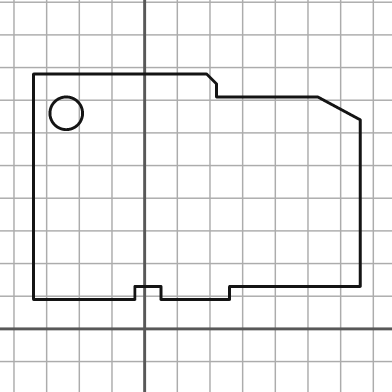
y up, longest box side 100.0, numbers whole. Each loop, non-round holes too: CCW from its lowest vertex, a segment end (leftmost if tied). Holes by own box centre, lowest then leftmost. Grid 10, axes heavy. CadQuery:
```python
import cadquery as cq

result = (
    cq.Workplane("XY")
    .moveTo(-34.0, 9.0)
    .lineTo(-3.0, 9.0)
    .lineTo(-3.0, 13.0)
    .lineTo(5.0, 13.0)
    .lineTo(5.0, 9.0)
    .lineTo(26.0, 9.0)
    .lineTo(26.0, 13.0)
    .lineTo(66.0, 13.0)
    .lineTo(66.0, 64.0)
    .lineTo(53.0, 71.0)
    .lineTo(22.0, 71.0)
    .lineTo(22.0, 75.0)
    .lineTo(19.0, 78.0)
    .lineTo(-34.0, 78.0)
    .close()
    .moveTo(-24.0, 66.0)
    .circle(5.0)
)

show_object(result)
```